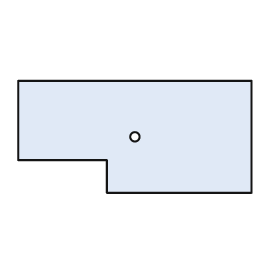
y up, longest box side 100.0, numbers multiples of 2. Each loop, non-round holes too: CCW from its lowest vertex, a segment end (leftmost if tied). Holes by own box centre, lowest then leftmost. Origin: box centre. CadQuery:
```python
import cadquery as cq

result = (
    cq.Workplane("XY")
    .moveTo(-12.0, -24.0)
    .lineTo(50.0, -24.0)
    .lineTo(50.0, 24.0)
    .lineTo(-50.0, 24.0)
    .lineTo(-50.0, -10.0)
    .lineTo(-12.0, -10.0)
    .close()
    .moveTo(0.0, 0.0)
    .circle(2.0)
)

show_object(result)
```